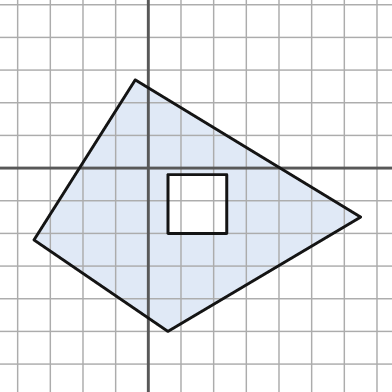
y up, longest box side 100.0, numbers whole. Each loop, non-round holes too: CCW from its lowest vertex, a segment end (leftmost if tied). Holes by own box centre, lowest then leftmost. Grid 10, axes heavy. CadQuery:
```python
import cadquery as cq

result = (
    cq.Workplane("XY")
    .moveTo(6.0, -50.0)
    .lineTo(65.0, -15.0)
    .lineTo(-4.0, 27.0)
    .lineTo(-35.0, -22.0)
    .close()
    .moveTo(6.0, -20.0)
    .lineTo(24.0, -20.0)
    .lineTo(24.0, -2.0)
    .lineTo(6.0, -2.0)
    .close()
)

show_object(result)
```